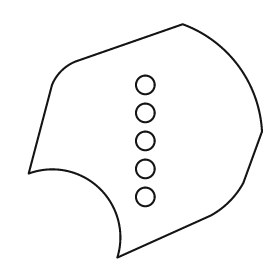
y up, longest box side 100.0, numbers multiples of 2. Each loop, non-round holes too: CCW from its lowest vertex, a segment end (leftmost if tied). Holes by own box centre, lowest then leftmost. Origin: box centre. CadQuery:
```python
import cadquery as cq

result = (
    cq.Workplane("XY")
    .moveTo(-12.0, -50.0)
    .lineTo(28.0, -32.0)
    .threePointArc((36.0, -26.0), (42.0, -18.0))
    .lineTo(50.0, 4.0)
    .threePointArc((40.0, 32.0), (16.0, 50.0))
    .lineTo(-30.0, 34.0)
    .threePointArc((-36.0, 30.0), (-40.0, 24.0))
    .lineTo(-50.0, -14.0)
    .threePointArc((-20.0, -20.0), (-12.0, -50.0))
    .close()
    .moveTo(0.0, -24.0)
    .circle(4.0)
    .moveTo(0.0, -12.0)
    .circle(4.0)
    .moveTo(0.0, 0.0)
    .circle(4.0)
    .moveTo(0.0, 12.0)
    .circle(4.0)
    .moveTo(0.0, 24.0)
    .circle(4.0)
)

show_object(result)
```